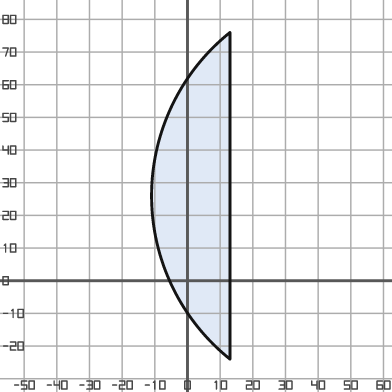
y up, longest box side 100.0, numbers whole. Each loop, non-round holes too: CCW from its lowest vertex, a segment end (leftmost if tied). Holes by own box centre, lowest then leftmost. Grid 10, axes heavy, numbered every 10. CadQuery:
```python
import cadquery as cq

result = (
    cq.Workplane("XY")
    .moveTo(13.0, -24.0)
    .lineTo(13.0, 76.0)
    .threePointArc((-11.0, 26.0), (13.0, -24.0))
    .close()
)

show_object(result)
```